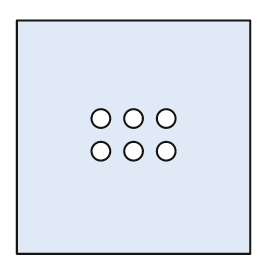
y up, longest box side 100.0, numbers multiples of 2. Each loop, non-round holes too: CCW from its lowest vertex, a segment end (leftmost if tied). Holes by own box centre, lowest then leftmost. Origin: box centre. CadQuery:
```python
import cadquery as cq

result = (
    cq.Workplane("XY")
    .moveTo(-50.0, -50.0)
    .lineTo(50.0, -50.0)
    .lineTo(50.0, 50.0)
    .lineTo(-50.0, 50.0)
    .close()
    .moveTo(-14.0, -6.0)
    .circle(4.0)
    .moveTo(0.0, -6.0)
    .circle(4.0)
    .moveTo(14.0, -6.0)
    .circle(4.0)
    .moveTo(-14.0, 8.0)
    .circle(4.0)
    .moveTo(0.0, 8.0)
    .circle(4.0)
    .moveTo(14.0, 8.0)
    .circle(4.0)
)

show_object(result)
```